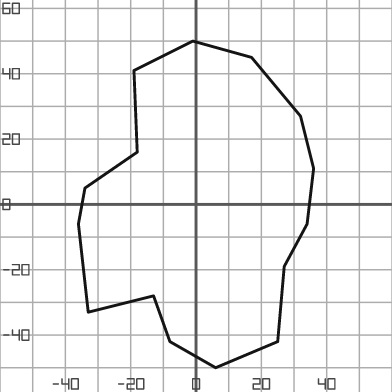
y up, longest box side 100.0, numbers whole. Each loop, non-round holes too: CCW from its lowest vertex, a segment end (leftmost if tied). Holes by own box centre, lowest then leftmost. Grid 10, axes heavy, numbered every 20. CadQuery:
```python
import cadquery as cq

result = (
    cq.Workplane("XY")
    .moveTo(6.0, -50.0)
    .lineTo(25.0, -42.0)
    .lineTo(27.0, -19.0)
    .lineTo(34.0, -6.0)
    .lineTo(36.0, 11.0)
    .lineTo(32.0, 27.0)
    .lineTo(17.0, 45.0)
    .lineTo(-1.0, 50.0)
    .lineTo(-19.0, 41.0)
    .lineTo(-18.0, 16.0)
    .lineTo(-34.0, 5.0)
    .lineTo(-36.0, -6.0)
    .lineTo(-33.0, -33.0)
    .lineTo(-13.0, -28.0)
    .lineTo(-8.0, -42.0)
    .close()
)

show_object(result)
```